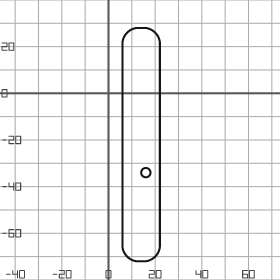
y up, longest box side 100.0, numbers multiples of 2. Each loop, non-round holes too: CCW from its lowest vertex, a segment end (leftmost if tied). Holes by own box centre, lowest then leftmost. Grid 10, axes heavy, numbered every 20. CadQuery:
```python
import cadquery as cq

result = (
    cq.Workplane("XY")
    .moveTo(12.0, -72.0)
    .lineTo(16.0, -72.0)
    .threePointArc((20.0, -70.0), (22.0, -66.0))
    .lineTo(22.0, 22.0)
    .threePointArc((20.0, 26.0), (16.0, 28.0))
    .lineTo(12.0, 28.0)
    .threePointArc((8.0, 26.0), (6.0, 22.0))
    .lineTo(6.0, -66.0)
    .threePointArc((8.0, -70.0), (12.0, -72.0))
    .close()
    .moveTo(16.0, -34.0)
    .circle(2.0)
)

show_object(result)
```